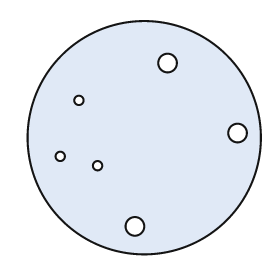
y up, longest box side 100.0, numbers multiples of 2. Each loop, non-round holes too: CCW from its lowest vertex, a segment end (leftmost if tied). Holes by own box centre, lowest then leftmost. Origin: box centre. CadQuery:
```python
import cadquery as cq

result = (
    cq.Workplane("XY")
    .moveTo(0.0, 0.0)
    .circle(50.0)
    .moveTo(-4.0, -38.0)
    .circle(4.0)
    .moveTo(-20.0, -12.0)
    .circle(2.0)
    .moveTo(-36.0, -8.0)
    .circle(2.0)
    .moveTo(40.0, 2.0)
    .circle(4.0)
    .moveTo(-28.0, 16.0)
    .circle(2.0)
    .moveTo(10.0, 32.0)
    .circle(4.0)
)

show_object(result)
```